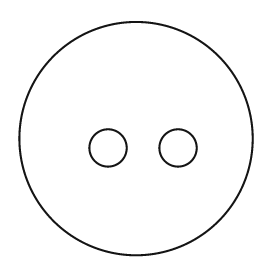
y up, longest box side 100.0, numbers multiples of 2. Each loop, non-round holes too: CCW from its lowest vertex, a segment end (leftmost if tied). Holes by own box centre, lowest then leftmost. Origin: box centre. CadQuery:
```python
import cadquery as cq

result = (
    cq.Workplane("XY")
    .moveTo(0.0, 0.0)
    .circle(50.0)
    .moveTo(-12.0, -4.0)
    .circle(8.0)
    .moveTo(18.0, -4.0)
    .circle(8.0)
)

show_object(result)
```